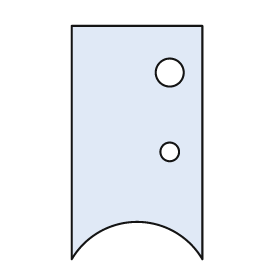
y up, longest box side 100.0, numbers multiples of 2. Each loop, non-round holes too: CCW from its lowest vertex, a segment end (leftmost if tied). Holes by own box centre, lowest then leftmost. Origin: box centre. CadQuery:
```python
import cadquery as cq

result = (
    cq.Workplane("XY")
    .moveTo(-28.0, -50.0)
    .threePointArc((0.0, -34.0), (28.0, -50.0))
    .lineTo(28.0, 50.0)
    .lineTo(-28.0, 50.0)
    .close()
    .moveTo(14.0, -4.0)
    .circle(4.0)
    .moveTo(14.0, 30.0)
    .circle(6.0)
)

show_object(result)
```